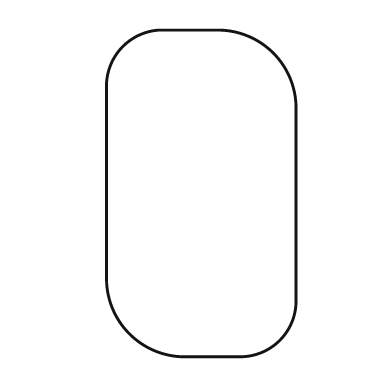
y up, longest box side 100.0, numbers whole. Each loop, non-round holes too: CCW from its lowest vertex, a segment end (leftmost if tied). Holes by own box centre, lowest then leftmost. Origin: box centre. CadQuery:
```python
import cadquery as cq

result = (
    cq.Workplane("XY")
    .moveTo(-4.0, -50.0)
    .lineTo(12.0, -50.0)
    .threePointArc((24.0, -45.0), (29.0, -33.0))
    .lineTo(29.0, 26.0)
    .threePointArc((22.0, 43.0), (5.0, 50.0))
    .lineTo(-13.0, 50.0)
    .threePointArc((-24.0, 45.0), (-29.0, 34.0))
    .lineTo(-29.0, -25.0)
    .threePointArc((-22.0, -43.0), (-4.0, -50.0))
    .close()
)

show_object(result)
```